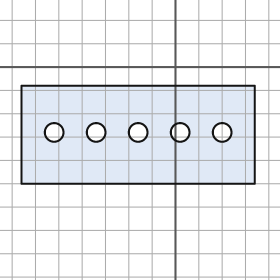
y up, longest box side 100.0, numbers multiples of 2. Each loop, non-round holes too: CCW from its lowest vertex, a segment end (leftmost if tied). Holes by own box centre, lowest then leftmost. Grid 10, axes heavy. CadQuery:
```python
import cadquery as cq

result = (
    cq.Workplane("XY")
    .moveTo(-66.0, -50.0)
    .lineTo(34.0, -50.0)
    .lineTo(34.0, -8.0)
    .lineTo(-66.0, -8.0)
    .close()
    .moveTo(-52.0, -28.0)
    .circle(4.0)
    .moveTo(-34.0, -28.0)
    .circle(4.0)
    .moveTo(-16.0, -28.0)
    .circle(4.0)
    .moveTo(2.0, -28.0)
    .circle(4.0)
    .moveTo(20.0, -28.0)
    .circle(4.0)
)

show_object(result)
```